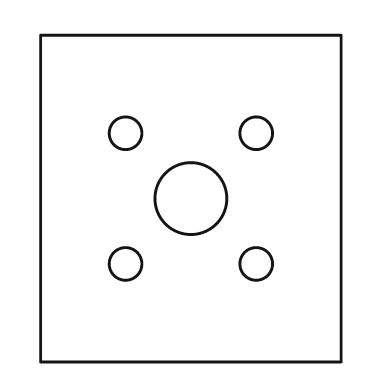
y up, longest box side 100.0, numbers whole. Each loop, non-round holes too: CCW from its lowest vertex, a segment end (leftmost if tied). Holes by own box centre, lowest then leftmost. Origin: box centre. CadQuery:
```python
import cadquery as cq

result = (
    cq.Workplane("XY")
    .moveTo(-46.0, -50.0)
    .lineTo(46.0, -50.0)
    .lineTo(46.0, 50.0)
    .lineTo(-46.0, 50.0)
    .close()
    .moveTo(-20.0, -20.0)
    .circle(5.0)
    .moveTo(20.0, -20.0)
    .circle(5.0)
    .moveTo(0.0, 0.0)
    .circle(11.0)
    .moveTo(-20.0, 20.0)
    .circle(5.0)
    .moveTo(20.0, 20.0)
    .circle(5.0)
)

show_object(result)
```